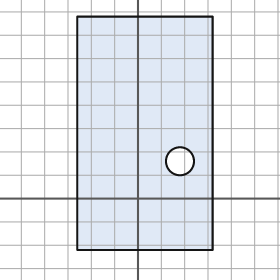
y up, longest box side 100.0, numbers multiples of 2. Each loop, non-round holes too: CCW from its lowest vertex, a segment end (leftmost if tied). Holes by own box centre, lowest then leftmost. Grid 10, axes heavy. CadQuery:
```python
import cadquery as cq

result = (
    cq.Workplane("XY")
    .moveTo(-26.0, -22.0)
    .lineTo(32.0, -22.0)
    .lineTo(32.0, 78.0)
    .lineTo(-26.0, 78.0)
    .close()
    .moveTo(18.0, 16.0)
    .circle(6.0)
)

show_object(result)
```